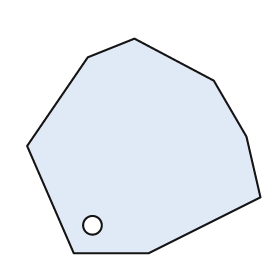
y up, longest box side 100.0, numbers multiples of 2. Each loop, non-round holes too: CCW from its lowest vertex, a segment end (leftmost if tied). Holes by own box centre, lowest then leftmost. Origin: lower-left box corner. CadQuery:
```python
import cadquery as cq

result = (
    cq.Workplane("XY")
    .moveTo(20.0, 0.0)
    .lineTo(52.0, 0.0)
    .lineTo(100.0, 24.0)
    .lineTo(94.0, 50.0)
    .lineTo(80.0, 74.0)
    .lineTo(46.0, 92.0)
    .lineTo(26.0, 84.0)
    .lineTo(0.0, 46.0)
    .close()
    .moveTo(28.0, 12.0)
    .circle(4.0)
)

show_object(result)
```